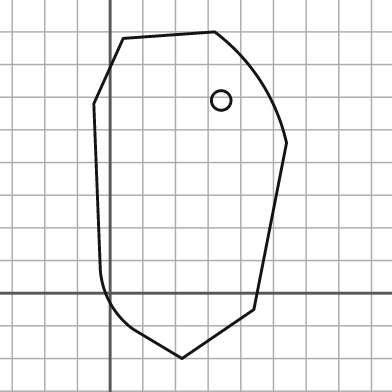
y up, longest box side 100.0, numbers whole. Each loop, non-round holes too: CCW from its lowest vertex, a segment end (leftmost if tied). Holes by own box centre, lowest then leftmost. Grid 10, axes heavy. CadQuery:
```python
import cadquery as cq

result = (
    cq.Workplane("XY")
    .moveTo(22.0, -20.0)
    .lineTo(44.0, -5.0)
    .lineTo(54.0, 46.0)
    .threePointArc((46.0, 65.0), (32.0, 80.0))
    .lineTo(4.0, 78.0)
    .lineTo(-5.0, 58.0)
    .lineTo(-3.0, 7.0)
    .threePointArc((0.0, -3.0), (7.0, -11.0))
    .close()
    .moveTo(34.0, 59.0)
    .circle(3.0)
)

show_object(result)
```